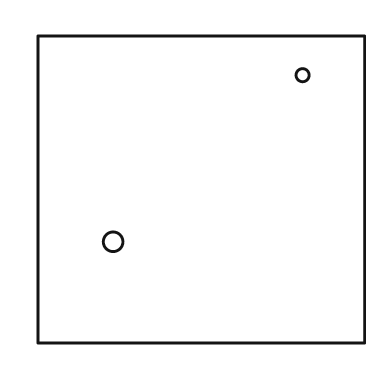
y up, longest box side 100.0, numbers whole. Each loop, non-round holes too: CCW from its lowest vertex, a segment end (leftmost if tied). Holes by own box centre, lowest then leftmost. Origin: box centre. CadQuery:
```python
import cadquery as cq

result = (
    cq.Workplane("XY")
    .moveTo(-50.0, -47.0)
    .lineTo(50.0, -47.0)
    .lineTo(50.0, 47.0)
    .lineTo(-50.0, 47.0)
    .close()
    .moveTo(-27.0, -16.0)
    .circle(3.0)
    .moveTo(31.0, 35.0)
    .circle(2.0)
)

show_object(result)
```